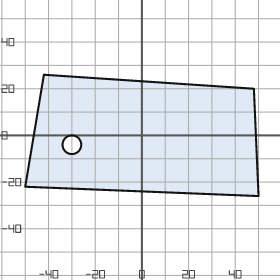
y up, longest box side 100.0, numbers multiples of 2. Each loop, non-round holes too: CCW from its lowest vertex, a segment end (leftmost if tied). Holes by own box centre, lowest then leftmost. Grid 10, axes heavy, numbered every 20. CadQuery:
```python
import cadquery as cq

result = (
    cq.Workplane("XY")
    .moveTo(50.0, -26.0)
    .lineTo(48.0, 20.0)
    .lineTo(-42.0, 26.0)
    .lineTo(-50.0, -22.0)
    .close()
    .moveTo(-30.0, -4.0)
    .circle(4.0)
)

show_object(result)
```